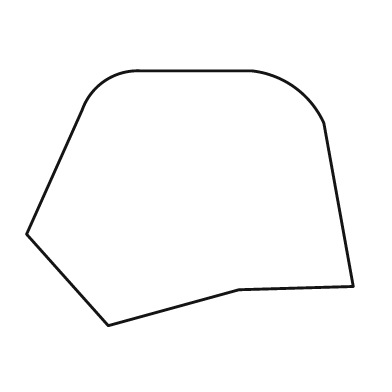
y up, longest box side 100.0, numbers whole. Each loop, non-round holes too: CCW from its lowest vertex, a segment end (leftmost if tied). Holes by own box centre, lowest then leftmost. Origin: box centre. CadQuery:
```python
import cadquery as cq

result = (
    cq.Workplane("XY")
    .moveTo(-25.0, -39.0)
    .lineTo(15.0, -28.0)
    .lineTo(50.0, -27.0)
    .lineTo(41.0, 23.0)
    .threePointArc((32.0, 34.0), (19.0, 39.0))
    .lineTo(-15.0, 39.0)
    .threePointArc((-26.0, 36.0), (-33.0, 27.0))
    .lineTo(-50.0, -11.0)
    .close()
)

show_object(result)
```